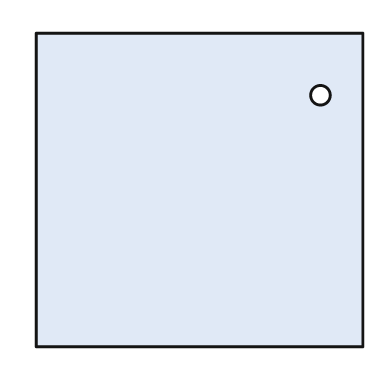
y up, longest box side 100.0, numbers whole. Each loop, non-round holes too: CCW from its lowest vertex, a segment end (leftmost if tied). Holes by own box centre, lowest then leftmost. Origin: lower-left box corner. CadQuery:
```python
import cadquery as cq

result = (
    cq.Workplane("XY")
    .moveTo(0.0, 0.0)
    .lineTo(100.0, 0.0)
    .lineTo(100.0, 96.0)
    .lineTo(0.0, 96.0)
    .close()
    .moveTo(87.0, 77.0)
    .circle(3.0)
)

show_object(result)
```